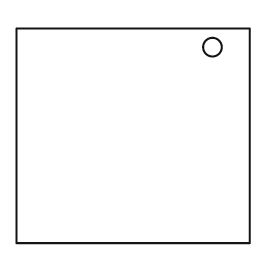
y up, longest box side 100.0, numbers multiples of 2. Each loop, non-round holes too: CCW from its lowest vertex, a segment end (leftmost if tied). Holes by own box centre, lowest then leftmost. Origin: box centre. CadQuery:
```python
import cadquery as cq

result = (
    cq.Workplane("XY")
    .moveTo(-50.0, -46.0)
    .lineTo(50.0, -46.0)
    .lineTo(50.0, 46.0)
    .lineTo(-50.0, 46.0)
    .close()
    .moveTo(34.0, 38.0)
    .circle(4.0)
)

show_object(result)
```